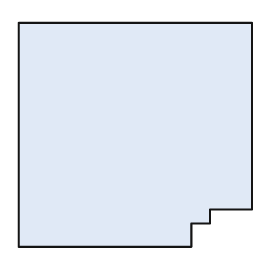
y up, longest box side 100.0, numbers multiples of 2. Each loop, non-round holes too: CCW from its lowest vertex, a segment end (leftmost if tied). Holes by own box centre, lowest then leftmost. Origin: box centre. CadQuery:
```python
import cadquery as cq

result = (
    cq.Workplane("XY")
    .moveTo(-50.0, -48.0)
    .lineTo(24.0, -48.0)
    .lineTo(24.0, -38.0)
    .lineTo(32.0, -38.0)
    .lineTo(32.0, -32.0)
    .lineTo(50.0, -32.0)
    .lineTo(50.0, 48.0)
    .lineTo(-50.0, 48.0)
    .close()
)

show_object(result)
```